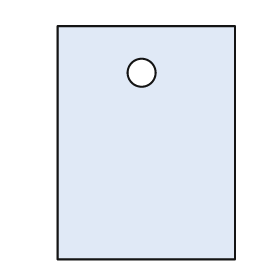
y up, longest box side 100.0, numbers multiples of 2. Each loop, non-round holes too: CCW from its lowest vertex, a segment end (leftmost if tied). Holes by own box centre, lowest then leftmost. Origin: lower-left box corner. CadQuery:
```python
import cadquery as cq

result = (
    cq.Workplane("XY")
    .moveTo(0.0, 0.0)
    .lineTo(76.0, 0.0)
    .lineTo(76.0, 100.0)
    .lineTo(0.0, 100.0)
    .close()
    .moveTo(36.0, 80.0)
    .circle(6.0)
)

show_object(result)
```